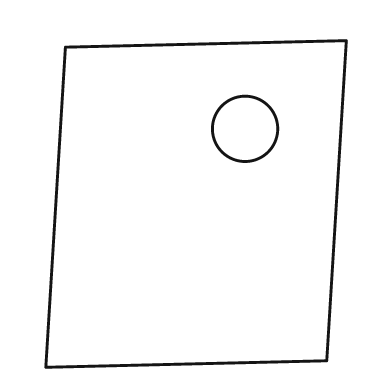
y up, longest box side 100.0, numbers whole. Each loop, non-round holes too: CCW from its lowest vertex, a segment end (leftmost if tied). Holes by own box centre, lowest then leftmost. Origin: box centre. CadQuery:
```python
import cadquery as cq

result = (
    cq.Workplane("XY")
    .moveTo(-46.0, -50.0)
    .lineTo(40.0, -48.0)
    .lineTo(46.0, 50.0)
    .lineTo(-40.0, 48.0)
    .close()
    .moveTo(15.0, 23.0)
    .circle(10.0)
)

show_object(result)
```